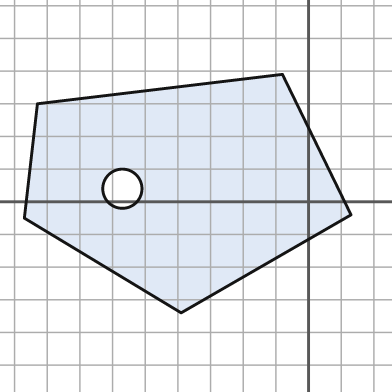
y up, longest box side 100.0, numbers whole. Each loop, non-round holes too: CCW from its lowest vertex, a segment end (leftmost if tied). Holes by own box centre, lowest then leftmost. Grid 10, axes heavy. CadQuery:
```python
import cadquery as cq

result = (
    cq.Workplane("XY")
    .moveTo(-39.0, -34.0)
    .lineTo(13.0, -4.0)
    .lineTo(-8.0, 39.0)
    .lineTo(-83.0, 30.0)
    .lineTo(-87.0, -5.0)
    .close()
    .moveTo(-57.0, 4.0)
    .circle(6.0)
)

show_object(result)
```